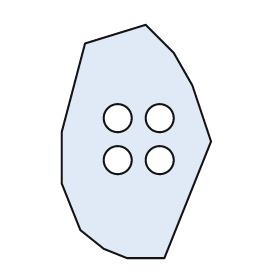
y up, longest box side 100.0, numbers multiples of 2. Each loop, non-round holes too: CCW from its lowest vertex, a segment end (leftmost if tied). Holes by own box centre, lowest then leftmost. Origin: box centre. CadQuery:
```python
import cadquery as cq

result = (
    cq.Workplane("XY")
    .moveTo(-4.0, -50.0)
    .lineTo(12.0, -50.0)
    .lineTo(32.0, 0.0)
    .lineTo(24.0, 24.0)
    .lineTo(16.0, 38.0)
    .lineTo(4.0, 50.0)
    .lineTo(-22.0, 42.0)
    .lineTo(-32.0, 4.0)
    .lineTo(-32.0, -18.0)
    .lineTo(-24.0, -38.0)
    .lineTo(-14.0, -46.0)
    .close()
    .moveTo(-8.0, -8.0)
    .circle(6.0)
    .moveTo(10.0, -8.0)
    .circle(6.0)
    .moveTo(-8.0, 10.0)
    .circle(6.0)
    .moveTo(10.0, 10.0)
    .circle(6.0)
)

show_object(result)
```